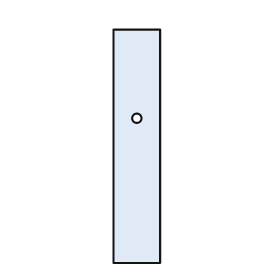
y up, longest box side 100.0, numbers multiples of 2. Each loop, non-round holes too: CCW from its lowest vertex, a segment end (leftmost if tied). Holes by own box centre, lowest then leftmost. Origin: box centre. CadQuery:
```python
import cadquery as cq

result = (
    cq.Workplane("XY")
    .moveTo(-10.0, -50.0)
    .lineTo(10.0, -50.0)
    .lineTo(10.0, 50.0)
    .lineTo(-10.0, 50.0)
    .close()
    .moveTo(0.0, 12.0)
    .circle(2.0)
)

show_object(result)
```